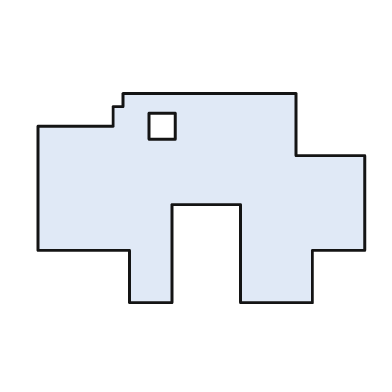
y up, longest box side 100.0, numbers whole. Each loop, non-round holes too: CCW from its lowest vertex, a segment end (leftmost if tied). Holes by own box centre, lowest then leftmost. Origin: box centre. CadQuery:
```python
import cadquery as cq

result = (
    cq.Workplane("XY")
    .moveTo(-22.0, -32.0)
    .lineTo(-9.0, -32.0)
    .lineTo(-9.0, -2.0)
    .lineTo(12.0, -2.0)
    .lineTo(12.0, -32.0)
    .lineTo(34.0, -32.0)
    .lineTo(34.0, -16.0)
    .lineTo(50.0, -16.0)
    .lineTo(50.0, 13.0)
    .lineTo(29.0, 13.0)
    .lineTo(29.0, 32.0)
    .lineTo(-24.0, 32.0)
    .lineTo(-24.0, 28.0)
    .lineTo(-27.0, 28.0)
    .lineTo(-27.0, 22.0)
    .lineTo(-50.0, 22.0)
    .lineTo(-50.0, -16.0)
    .lineTo(-22.0, -16.0)
    .close()
    .moveTo(-16.0, 18.0)
    .lineTo(-8.0, 18.0)
    .lineTo(-8.0, 26.0)
    .lineTo(-16.0, 26.0)
    .close()
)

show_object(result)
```